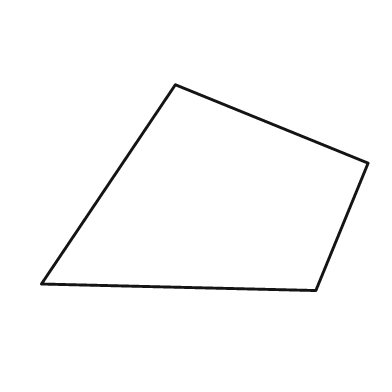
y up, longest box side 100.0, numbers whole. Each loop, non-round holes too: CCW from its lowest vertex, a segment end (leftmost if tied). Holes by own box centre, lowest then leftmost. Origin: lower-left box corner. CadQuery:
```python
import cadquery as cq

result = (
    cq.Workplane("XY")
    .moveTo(84.0, 0.0)
    .lineTo(100.0, 39.0)
    .lineTo(41.0, 63.0)
    .lineTo(0.0, 2.0)
    .close()
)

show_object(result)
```